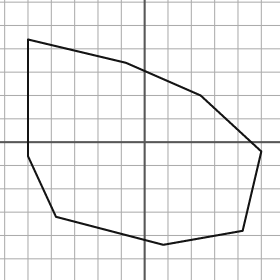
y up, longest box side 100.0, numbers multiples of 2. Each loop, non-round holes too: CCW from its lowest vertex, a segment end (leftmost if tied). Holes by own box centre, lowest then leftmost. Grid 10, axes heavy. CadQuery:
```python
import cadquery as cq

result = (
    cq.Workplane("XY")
    .moveTo(8.0, -44.0)
    .lineTo(42.0, -38.0)
    .lineTo(50.0, -4.0)
    .lineTo(24.0, 20.0)
    .lineTo(-8.0, 34.0)
    .lineTo(-50.0, 44.0)
    .lineTo(-50.0, -6.0)
    .lineTo(-38.0, -32.0)
    .close()
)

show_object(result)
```